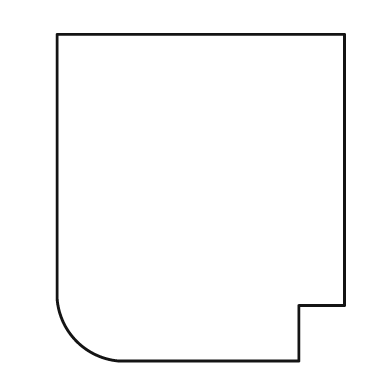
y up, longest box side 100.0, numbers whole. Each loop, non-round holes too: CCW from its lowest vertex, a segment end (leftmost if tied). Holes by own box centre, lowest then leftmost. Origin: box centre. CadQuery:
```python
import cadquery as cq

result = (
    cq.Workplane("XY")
    .moveTo(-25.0, -50.0)
    .lineTo(30.0, -50.0)
    .lineTo(30.0, -33.0)
    .lineTo(44.0, -33.0)
    .lineTo(44.0, 50.0)
    .lineTo(-44.0, 50.0)
    .lineTo(-44.0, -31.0)
    .threePointArc((-38.0, -44.0), (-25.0, -50.0))
    .close()
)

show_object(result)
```